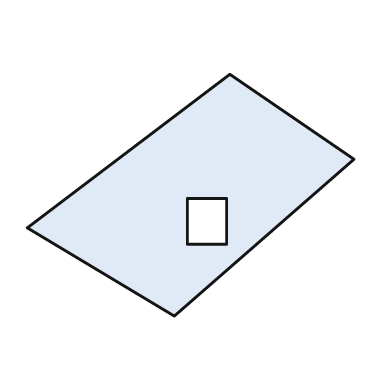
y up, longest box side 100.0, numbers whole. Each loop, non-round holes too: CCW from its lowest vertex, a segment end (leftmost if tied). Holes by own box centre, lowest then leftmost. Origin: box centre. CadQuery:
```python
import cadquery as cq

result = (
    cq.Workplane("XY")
    .moveTo(-5.0, -37.0)
    .lineTo(50.0, 11.0)
    .lineTo(12.0, 37.0)
    .lineTo(-50.0, -10.0)
    .close()
    .moveTo(-1.0, -15.0)
    .lineTo(11.0, -15.0)
    .lineTo(11.0, -1.0)
    .lineTo(-1.0, -1.0)
    .close()
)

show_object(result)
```